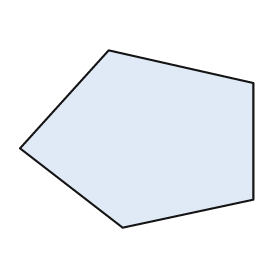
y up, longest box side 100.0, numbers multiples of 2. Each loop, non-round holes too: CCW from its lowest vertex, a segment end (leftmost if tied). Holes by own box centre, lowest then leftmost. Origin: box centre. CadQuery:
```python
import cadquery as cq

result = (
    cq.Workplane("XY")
    .moveTo(-6.0, -38.0)
    .lineTo(50.0, -26.0)
    .lineTo(50.0, 24.0)
    .lineTo(-12.0, 38.0)
    .lineTo(-50.0, -4.0)
    .close()
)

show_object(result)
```